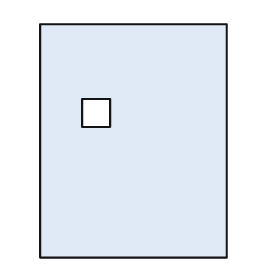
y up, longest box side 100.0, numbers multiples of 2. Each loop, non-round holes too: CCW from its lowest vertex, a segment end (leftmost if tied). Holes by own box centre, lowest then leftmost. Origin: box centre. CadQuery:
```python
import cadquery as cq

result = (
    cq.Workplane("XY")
    .moveTo(-40.0, -50.0)
    .lineTo(40.0, -50.0)
    .lineTo(40.0, 50.0)
    .lineTo(-40.0, 50.0)
    .close()
    .moveTo(-22.0, 6.0)
    .lineTo(-10.0, 6.0)
    .lineTo(-10.0, 18.0)
    .lineTo(-22.0, 18.0)
    .close()
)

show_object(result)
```